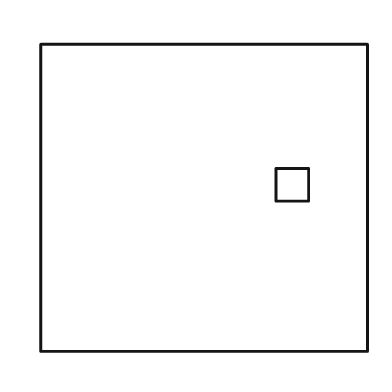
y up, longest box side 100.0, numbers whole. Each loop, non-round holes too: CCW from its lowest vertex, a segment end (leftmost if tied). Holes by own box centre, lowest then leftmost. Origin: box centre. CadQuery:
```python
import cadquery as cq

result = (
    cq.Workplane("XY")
    .moveTo(-50.0, -47.0)
    .lineTo(50.0, -47.0)
    .lineTo(50.0, 47.0)
    .lineTo(-50.0, 47.0)
    .close()
    .moveTo(22.0, -1.0)
    .lineTo(32.0, -1.0)
    .lineTo(32.0, 9.0)
    .lineTo(22.0, 9.0)
    .close()
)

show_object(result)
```